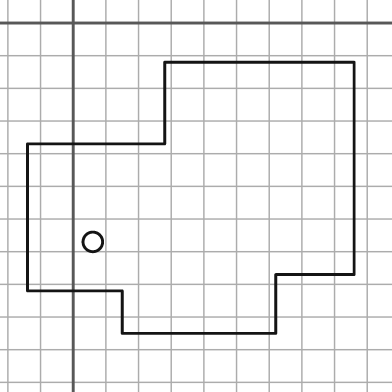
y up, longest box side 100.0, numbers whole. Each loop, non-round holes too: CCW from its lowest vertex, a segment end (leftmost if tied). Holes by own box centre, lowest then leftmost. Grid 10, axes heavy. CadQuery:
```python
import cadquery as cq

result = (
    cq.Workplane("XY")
    .moveTo(15.0, -95.0)
    .lineTo(62.0, -95.0)
    .lineTo(62.0, -77.0)
    .lineTo(86.0, -77.0)
    .lineTo(86.0, -12.0)
    .lineTo(28.0, -12.0)
    .lineTo(28.0, -37.0)
    .lineTo(-14.0, -37.0)
    .lineTo(-14.0, -82.0)
    .lineTo(15.0, -82.0)
    .close()
    .moveTo(6.0, -67.0)
    .circle(3.0)
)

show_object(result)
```